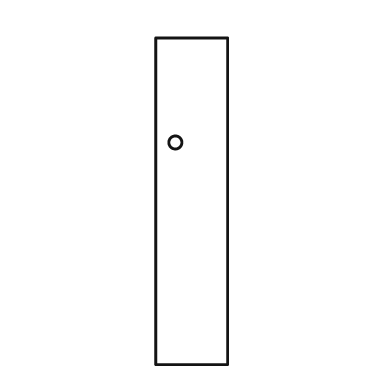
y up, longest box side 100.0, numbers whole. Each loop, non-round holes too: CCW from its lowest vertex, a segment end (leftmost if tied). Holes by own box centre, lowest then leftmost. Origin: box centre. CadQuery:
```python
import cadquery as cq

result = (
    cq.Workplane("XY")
    .moveTo(-11.0, -50.0)
    .lineTo(11.0, -50.0)
    .lineTo(11.0, 50.0)
    .lineTo(-11.0, 50.0)
    .close()
    .moveTo(-5.0, 18.0)
    .circle(2.0)
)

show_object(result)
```